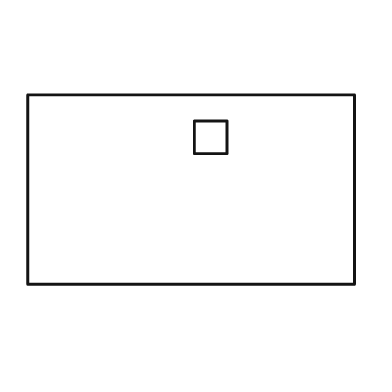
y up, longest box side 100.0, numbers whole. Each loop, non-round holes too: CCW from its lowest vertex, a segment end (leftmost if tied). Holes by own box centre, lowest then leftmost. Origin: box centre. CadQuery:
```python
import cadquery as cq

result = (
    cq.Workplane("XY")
    .moveTo(-50.0, -29.0)
    .lineTo(50.0, -29.0)
    .lineTo(50.0, 29.0)
    .lineTo(-50.0, 29.0)
    .close()
    .moveTo(1.0, 11.0)
    .lineTo(11.0, 11.0)
    .lineTo(11.0, 21.0)
    .lineTo(1.0, 21.0)
    .close()
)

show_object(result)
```